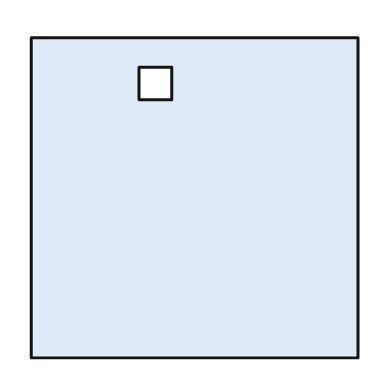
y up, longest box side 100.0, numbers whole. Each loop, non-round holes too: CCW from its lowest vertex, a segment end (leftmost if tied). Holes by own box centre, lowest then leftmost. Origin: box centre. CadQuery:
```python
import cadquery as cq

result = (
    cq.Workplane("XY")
    .moveTo(-50.0, -49.0)
    .lineTo(50.0, -49.0)
    .lineTo(50.0, 49.0)
    .lineTo(-50.0, 49.0)
    .close()
    .moveTo(-17.0, 30.0)
    .lineTo(-7.0, 30.0)
    .lineTo(-7.0, 40.0)
    .lineTo(-17.0, 40.0)
    .close()
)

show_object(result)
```